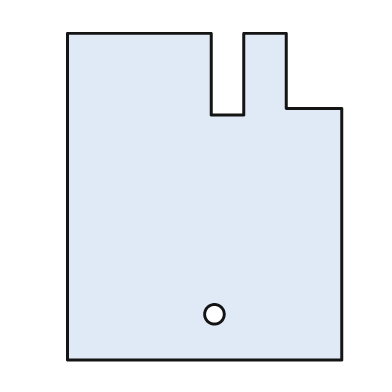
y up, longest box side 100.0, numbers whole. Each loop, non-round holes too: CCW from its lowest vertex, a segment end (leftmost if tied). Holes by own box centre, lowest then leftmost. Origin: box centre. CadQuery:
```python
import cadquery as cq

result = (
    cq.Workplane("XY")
    .moveTo(-42.0, -50.0)
    .lineTo(42.0, -50.0)
    .lineTo(42.0, 27.0)
    .lineTo(25.0, 27.0)
    .lineTo(25.0, 50.0)
    .lineTo(12.0, 50.0)
    .lineTo(12.0, 25.0)
    .lineTo(2.0, 25.0)
    .lineTo(2.0, 50.0)
    .lineTo(-42.0, 50.0)
    .close()
    .moveTo(3.0, -36.0)
    .circle(3.0)
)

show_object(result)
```